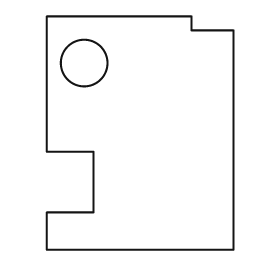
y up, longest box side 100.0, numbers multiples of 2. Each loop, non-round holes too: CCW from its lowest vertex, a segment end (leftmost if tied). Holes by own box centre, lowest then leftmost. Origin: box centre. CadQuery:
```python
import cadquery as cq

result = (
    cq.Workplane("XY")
    .moveTo(-40.0, -50.0)
    .lineTo(40.0, -50.0)
    .lineTo(40.0, 44.0)
    .lineTo(22.0, 44.0)
    .lineTo(22.0, 50.0)
    .lineTo(-40.0, 50.0)
    .lineTo(-40.0, -8.0)
    .lineTo(-20.0, -8.0)
    .lineTo(-20.0, -34.0)
    .lineTo(-40.0, -34.0)
    .close()
    .moveTo(-24.0, 30.0)
    .circle(10.0)
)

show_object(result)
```